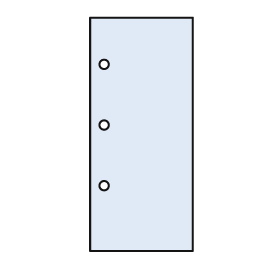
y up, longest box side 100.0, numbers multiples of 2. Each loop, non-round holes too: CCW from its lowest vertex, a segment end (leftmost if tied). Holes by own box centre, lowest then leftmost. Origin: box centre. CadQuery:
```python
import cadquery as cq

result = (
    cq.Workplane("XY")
    .moveTo(-22.0, -50.0)
    .lineTo(22.0, -50.0)
    .lineTo(22.0, 50.0)
    .lineTo(-22.0, 50.0)
    .close()
    .moveTo(-16.0, -22.0)
    .circle(2.0)
    .moveTo(-16.0, 4.0)
    .circle(2.0)
    .moveTo(-16.0, 30.0)
    .circle(2.0)
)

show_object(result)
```